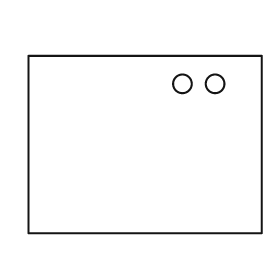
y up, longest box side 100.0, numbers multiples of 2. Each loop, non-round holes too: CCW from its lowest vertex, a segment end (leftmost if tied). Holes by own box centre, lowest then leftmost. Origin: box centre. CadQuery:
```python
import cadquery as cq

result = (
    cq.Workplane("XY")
    .moveTo(-50.0, -38.0)
    .lineTo(50.0, -38.0)
    .lineTo(50.0, 38.0)
    .lineTo(-50.0, 38.0)
    .close()
    .moveTo(16.0, 26.0)
    .circle(4.0)
    .moveTo(30.0, 26.0)
    .circle(4.0)
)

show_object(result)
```